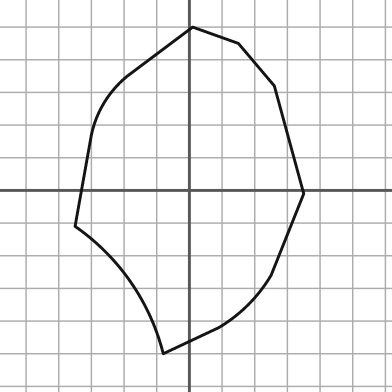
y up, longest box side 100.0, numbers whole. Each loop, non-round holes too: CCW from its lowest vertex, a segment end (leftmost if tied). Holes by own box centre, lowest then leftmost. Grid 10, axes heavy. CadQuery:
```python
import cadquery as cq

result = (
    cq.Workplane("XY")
    .moveTo(-8.0, -50.0)
    .lineTo(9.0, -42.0)
    .threePointArc((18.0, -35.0), (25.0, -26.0))
    .lineTo(35.0, -1.0)
    .lineTo(26.0, 32.0)
    .lineTo(15.0, 45.0)
    .lineTo(1.0, 50.0)
    .lineTo(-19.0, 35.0)
    .threePointArc((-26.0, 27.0), (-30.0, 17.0))
    .lineTo(-35.0, -11.0)
    .threePointArc((-18.0, -28.0), (-8.0, -50.0))
    .close()
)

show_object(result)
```